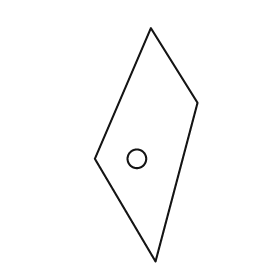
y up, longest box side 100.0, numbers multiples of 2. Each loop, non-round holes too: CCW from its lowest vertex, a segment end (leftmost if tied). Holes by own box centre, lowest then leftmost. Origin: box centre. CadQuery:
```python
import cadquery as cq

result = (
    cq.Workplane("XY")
    .moveTo(4.0, -50.0)
    .lineTo(22.0, 18.0)
    .lineTo(2.0, 50.0)
    .lineTo(-22.0, -6.0)
    .close()
    .moveTo(-4.0, -6.0)
    .circle(4.0)
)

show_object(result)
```